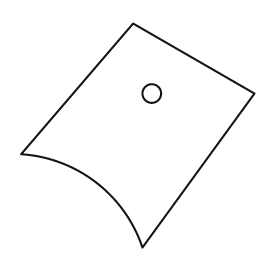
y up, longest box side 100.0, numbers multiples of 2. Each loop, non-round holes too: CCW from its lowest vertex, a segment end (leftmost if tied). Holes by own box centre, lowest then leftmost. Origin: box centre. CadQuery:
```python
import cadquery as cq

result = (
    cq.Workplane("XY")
    .moveTo(2.0, -48.0)
    .lineTo(50.0, 18.0)
    .lineTo(-2.0, 48.0)
    .lineTo(-50.0, -8.0)
    .threePointArc((-18.0, -20.0), (2.0, -48.0))
    .close()
    .moveTo(6.0, 18.0)
    .circle(4.0)
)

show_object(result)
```